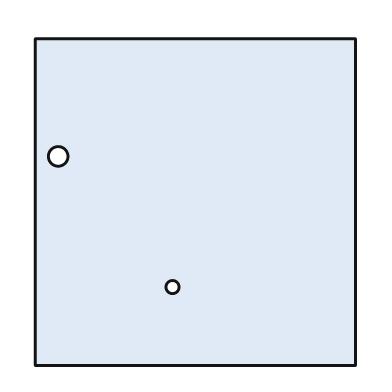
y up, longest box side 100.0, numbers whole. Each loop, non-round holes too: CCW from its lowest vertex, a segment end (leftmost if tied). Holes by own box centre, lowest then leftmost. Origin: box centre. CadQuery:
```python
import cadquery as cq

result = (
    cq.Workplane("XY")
    .moveTo(-49.0, -50.0)
    .lineTo(49.0, -50.0)
    .lineTo(49.0, 50.0)
    .lineTo(-49.0, 50.0)
    .close()
    .moveTo(-7.0, -26.0)
    .circle(2.0)
    .moveTo(-42.0, 14.0)
    .circle(3.0)
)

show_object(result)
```